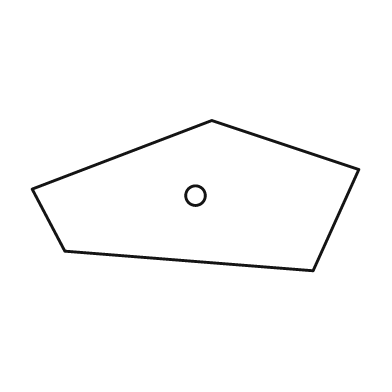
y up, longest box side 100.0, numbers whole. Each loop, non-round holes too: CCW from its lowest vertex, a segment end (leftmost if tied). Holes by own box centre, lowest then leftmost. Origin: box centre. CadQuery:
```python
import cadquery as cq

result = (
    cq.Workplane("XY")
    .moveTo(36.0, -23.0)
    .lineTo(50.0, 8.0)
    .lineTo(5.0, 23.0)
    .lineTo(-50.0, 2.0)
    .lineTo(-40.0, -17.0)
    .close()
    .moveTo(0.0, 0.0)
    .circle(3.0)
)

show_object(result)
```